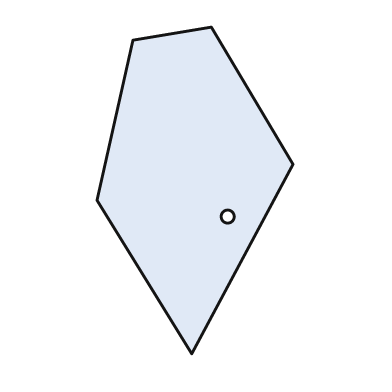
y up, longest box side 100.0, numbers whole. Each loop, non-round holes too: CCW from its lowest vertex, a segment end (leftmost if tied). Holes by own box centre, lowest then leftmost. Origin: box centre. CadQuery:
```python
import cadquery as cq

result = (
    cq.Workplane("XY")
    .moveTo(-1.0, -50.0)
    .lineTo(30.0, 8.0)
    .lineTo(5.0, 50.0)
    .lineTo(-19.0, 46.0)
    .lineTo(-30.0, -3.0)
    .close()
    .moveTo(10.0, -8.0)
    .circle(2.0)
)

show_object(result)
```